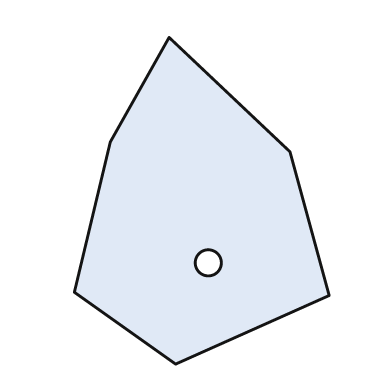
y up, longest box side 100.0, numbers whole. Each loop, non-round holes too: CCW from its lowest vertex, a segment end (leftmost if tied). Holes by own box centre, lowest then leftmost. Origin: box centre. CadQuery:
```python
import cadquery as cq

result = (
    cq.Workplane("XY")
    .moveTo(-8.0, -50.0)
    .lineTo(39.0, -29.0)
    .lineTo(27.0, 15.0)
    .lineTo(-10.0, 50.0)
    .lineTo(-28.0, 18.0)
    .lineTo(-39.0, -28.0)
    .close()
    .moveTo(2.0, -19.0)
    .circle(4.0)
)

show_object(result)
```